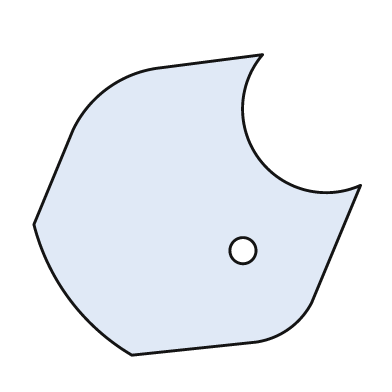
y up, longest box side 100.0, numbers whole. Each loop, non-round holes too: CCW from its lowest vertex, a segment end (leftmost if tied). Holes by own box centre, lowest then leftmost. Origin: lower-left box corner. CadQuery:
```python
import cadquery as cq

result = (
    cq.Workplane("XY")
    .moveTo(30.0, 0.0)
    .lineTo(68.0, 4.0)
    .threePointArc((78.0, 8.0), (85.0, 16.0))
    .lineTo(100.0, 52.0)
    .threePointArc((69.0, 60.0), (70.0, 92.0))
    .lineTo(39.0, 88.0)
    .threePointArc((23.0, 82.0), (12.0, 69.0))
    .lineTo(0.0, 40.0)
    .threePointArc((11.0, 17.0), (30.0, 0.0))
    .close()
    .moveTo(64.0, 32.0)
    .circle(4.0)
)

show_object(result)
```